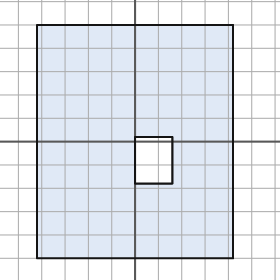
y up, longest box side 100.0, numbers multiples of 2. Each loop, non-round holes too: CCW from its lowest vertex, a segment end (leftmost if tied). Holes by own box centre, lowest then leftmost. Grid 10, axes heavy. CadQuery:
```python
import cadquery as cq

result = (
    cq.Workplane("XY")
    .moveTo(-42.0, -50.0)
    .lineTo(42.0, -50.0)
    .lineTo(42.0, 50.0)
    .lineTo(-42.0, 50.0)
    .close()
    .moveTo(0.0, -18.0)
    .lineTo(16.0, -18.0)
    .lineTo(16.0, 2.0)
    .lineTo(0.0, 2.0)
    .close()
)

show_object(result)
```